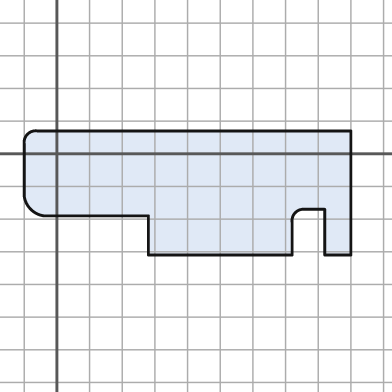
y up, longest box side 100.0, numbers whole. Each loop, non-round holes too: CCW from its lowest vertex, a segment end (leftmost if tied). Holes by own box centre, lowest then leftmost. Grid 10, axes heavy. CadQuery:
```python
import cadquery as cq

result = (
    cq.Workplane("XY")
    .moveTo(28.0, -31.0)
    .lineTo(72.0, -31.0)
    .lineTo(72.0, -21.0)
    .threePointArc((73.0, -18.0), (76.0, -17.0))
    .lineTo(82.0, -17.0)
    .lineTo(82.0, -31.0)
    .lineTo(90.0, -31.0)
    .lineTo(90.0, 7.0)
    .lineTo(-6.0, 7.0)
    .threePointArc((-9.0, 6.0), (-10.0, 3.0))
    .lineTo(-10.0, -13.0)
    .threePointArc((-8.0, -17.0), (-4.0, -19.0))
    .lineTo(28.0, -19.0)
    .close()
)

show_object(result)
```